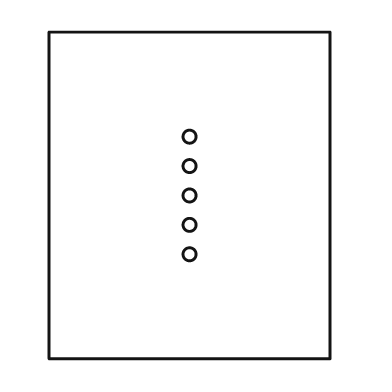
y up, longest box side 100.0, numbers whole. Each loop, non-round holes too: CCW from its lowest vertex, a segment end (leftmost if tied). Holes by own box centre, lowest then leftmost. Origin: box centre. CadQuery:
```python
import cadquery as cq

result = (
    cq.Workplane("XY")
    .moveTo(-43.0, -50.0)
    .lineTo(43.0, -50.0)
    .lineTo(43.0, 50.0)
    .lineTo(-43.0, 50.0)
    .close()
    .moveTo(0.0, -18.0)
    .circle(2.0)
    .moveTo(0.0, -9.0)
    .circle(2.0)
    .moveTo(0.0, 0.0)
    .circle(2.0)
    .moveTo(0.0, 9.0)
    .circle(2.0)
    .moveTo(0.0, 18.0)
    .circle(2.0)
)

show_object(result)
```